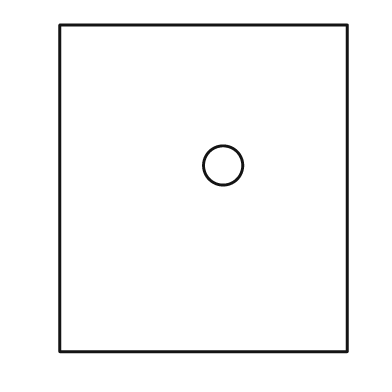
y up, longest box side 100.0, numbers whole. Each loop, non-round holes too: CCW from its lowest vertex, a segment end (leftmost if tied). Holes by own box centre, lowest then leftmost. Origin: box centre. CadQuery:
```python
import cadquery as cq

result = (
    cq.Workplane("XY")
    .moveTo(-44.0, -50.0)
    .lineTo(44.0, -50.0)
    .lineTo(44.0, 50.0)
    .lineTo(-44.0, 50.0)
    .close()
    .moveTo(6.0, 7.0)
    .circle(6.0)
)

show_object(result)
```